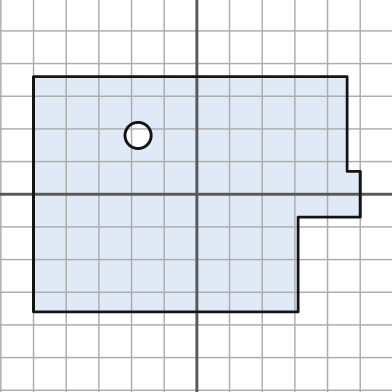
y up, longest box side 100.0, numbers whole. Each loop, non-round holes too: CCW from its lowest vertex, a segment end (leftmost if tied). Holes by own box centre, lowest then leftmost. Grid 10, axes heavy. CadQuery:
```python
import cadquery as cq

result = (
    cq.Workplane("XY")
    .moveTo(-50.0, -36.0)
    .lineTo(31.0, -36.0)
    .lineTo(31.0, -7.0)
    .lineTo(50.0, -7.0)
    .lineTo(50.0, 7.0)
    .lineTo(46.0, 7.0)
    .lineTo(46.0, 36.0)
    .lineTo(-50.0, 36.0)
    .close()
    .moveTo(-18.0, 18.0)
    .circle(4.0)
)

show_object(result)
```